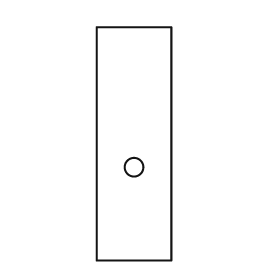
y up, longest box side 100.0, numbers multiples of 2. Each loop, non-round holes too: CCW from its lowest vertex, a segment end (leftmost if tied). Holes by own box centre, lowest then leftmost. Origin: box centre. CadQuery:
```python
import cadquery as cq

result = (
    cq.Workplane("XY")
    .moveTo(-16.0, -50.0)
    .lineTo(16.0, -50.0)
    .lineTo(16.0, 50.0)
    .lineTo(-16.0, 50.0)
    .close()
    .moveTo(0.0, -10.0)
    .circle(4.0)
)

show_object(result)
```